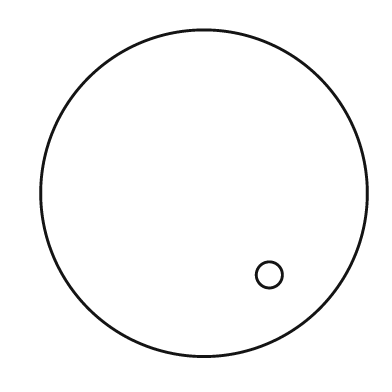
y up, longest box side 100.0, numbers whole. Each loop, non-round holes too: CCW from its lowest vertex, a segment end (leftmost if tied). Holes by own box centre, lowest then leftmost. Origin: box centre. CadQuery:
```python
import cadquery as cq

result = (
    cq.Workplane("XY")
    .moveTo(0.0, 0.0)
    .circle(50.0)
    .moveTo(20.0, -25.0)
    .circle(4.0)
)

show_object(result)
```